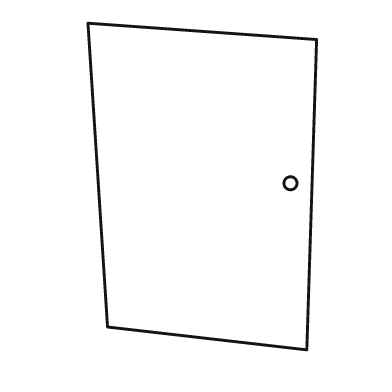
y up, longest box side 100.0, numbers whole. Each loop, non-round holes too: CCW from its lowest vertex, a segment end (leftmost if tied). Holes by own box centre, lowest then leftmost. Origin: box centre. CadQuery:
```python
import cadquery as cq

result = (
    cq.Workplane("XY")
    .moveTo(32.0, -50.0)
    .lineTo(35.0, 45.0)
    .lineTo(-35.0, 50.0)
    .lineTo(-29.0, -43.0)
    .close()
    .moveTo(27.0, 1.0)
    .circle(2.0)
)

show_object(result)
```